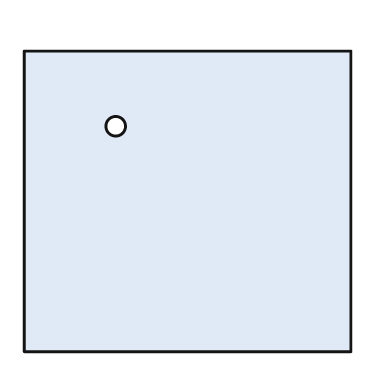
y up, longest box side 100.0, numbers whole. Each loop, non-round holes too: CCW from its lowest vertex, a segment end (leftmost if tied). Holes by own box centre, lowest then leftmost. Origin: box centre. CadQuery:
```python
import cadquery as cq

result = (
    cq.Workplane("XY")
    .moveTo(-50.0, -46.0)
    .lineTo(50.0, -46.0)
    .lineTo(50.0, 46.0)
    .lineTo(-50.0, 46.0)
    .close()
    .moveTo(-22.0, 23.0)
    .circle(3.0)
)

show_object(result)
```